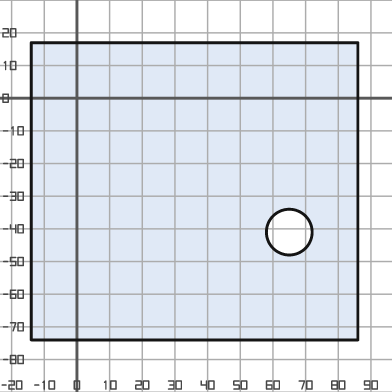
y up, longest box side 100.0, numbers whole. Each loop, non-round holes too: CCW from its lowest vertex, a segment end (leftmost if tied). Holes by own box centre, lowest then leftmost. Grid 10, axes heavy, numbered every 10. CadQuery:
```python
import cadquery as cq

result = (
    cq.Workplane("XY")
    .moveTo(-14.0, -74.0)
    .lineTo(86.0, -74.0)
    .lineTo(86.0, 17.0)
    .lineTo(-14.0, 17.0)
    .close()
    .moveTo(65.0, -41.0)
    .circle(7.0)
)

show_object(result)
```